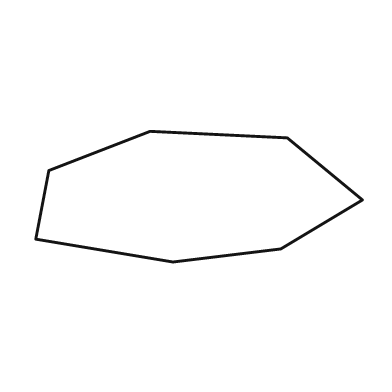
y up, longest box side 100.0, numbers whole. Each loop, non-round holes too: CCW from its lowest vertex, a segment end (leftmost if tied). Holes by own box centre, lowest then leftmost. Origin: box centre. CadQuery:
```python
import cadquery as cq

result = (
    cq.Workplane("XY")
    .moveTo(-8.0, -20.0)
    .lineTo(25.0, -16.0)
    .lineTo(50.0, -1.0)
    .lineTo(27.0, 18.0)
    .lineTo(-15.0, 20.0)
    .lineTo(-46.0, 8.0)
    .lineTo(-50.0, -13.0)
    .close()
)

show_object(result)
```